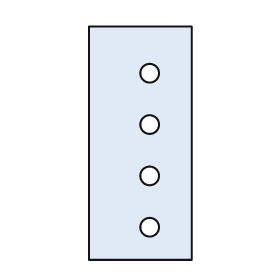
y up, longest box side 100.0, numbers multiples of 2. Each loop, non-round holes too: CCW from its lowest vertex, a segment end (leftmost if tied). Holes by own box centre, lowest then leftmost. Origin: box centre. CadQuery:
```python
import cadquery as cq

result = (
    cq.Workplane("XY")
    .moveTo(-22.0, -50.0)
    .lineTo(22.0, -50.0)
    .lineTo(22.0, 50.0)
    .lineTo(-22.0, 50.0)
    .close()
    .moveTo(4.0, -36.0)
    .circle(4.0)
    .moveTo(4.0, -14.0)
    .circle(4.0)
    .moveTo(4.0, 8.0)
    .circle(4.0)
    .moveTo(4.0, 30.0)
    .circle(4.0)
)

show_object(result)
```